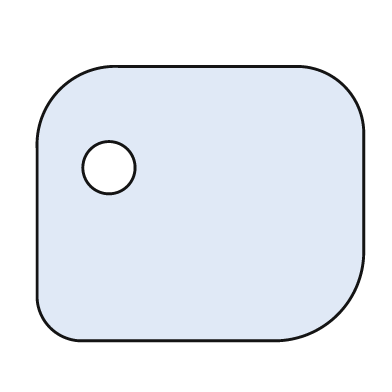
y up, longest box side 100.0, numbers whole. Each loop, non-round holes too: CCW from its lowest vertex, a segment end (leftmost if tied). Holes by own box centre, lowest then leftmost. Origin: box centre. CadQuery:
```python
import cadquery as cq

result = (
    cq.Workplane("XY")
    .moveTo(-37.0, -42.0)
    .lineTo(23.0, -42.0)
    .threePointArc((42.0, -34.0), (50.0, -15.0))
    .lineTo(50.0, 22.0)
    .threePointArc((44.0, 36.0), (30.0, 42.0))
    .lineTo(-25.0, 42.0)
    .threePointArc((-43.0, 35.0), (-50.0, 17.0))
    .lineTo(-50.0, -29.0)
    .threePointArc((-46.0, -38.0), (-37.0, -42.0))
    .close()
    .moveTo(-28.0, 11.0)
    .circle(8.0)
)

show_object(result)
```